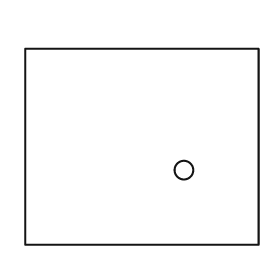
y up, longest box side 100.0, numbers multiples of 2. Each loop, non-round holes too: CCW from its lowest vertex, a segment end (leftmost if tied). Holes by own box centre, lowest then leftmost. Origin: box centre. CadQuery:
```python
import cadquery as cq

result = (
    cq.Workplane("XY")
    .moveTo(-50.0, -42.0)
    .lineTo(50.0, -42.0)
    .lineTo(50.0, 42.0)
    .lineTo(-50.0, 42.0)
    .close()
    .moveTo(18.0, -10.0)
    .circle(4.0)
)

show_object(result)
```